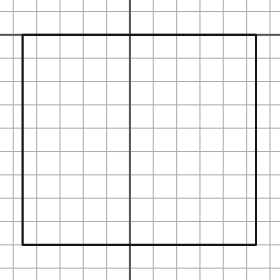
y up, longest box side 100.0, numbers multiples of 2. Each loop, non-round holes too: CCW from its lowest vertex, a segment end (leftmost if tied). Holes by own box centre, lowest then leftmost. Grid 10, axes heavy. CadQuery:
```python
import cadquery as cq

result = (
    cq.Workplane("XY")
    .moveTo(-46.0, -90.0)
    .lineTo(54.0, -90.0)
    .lineTo(54.0, 0.0)
    .lineTo(-46.0, 0.0)
    .close()
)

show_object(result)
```